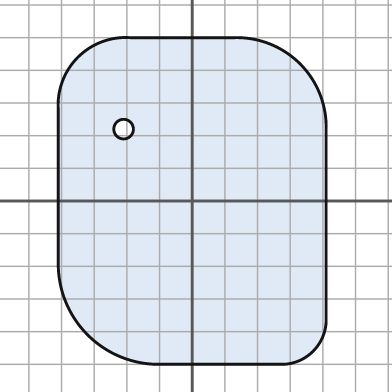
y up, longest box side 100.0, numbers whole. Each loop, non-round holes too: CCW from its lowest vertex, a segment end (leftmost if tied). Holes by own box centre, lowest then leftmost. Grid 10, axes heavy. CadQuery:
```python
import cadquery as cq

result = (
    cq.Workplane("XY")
    .moveTo(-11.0, -50.0)
    .lineTo(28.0, -50.0)
    .threePointArc((37.0, -46.0), (41.0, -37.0))
    .lineTo(41.0, 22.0)
    .threePointArc((33.0, 42.0), (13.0, 50.0))
    .lineTo(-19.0, 50.0)
    .threePointArc((-35.0, 44.0), (-41.0, 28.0))
    .lineTo(-41.0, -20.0)
    .threePointArc((-32.0, -41.0), (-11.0, -50.0))
    .close()
    .moveTo(-21.0, 22.0)
    .circle(3.0)
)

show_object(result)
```